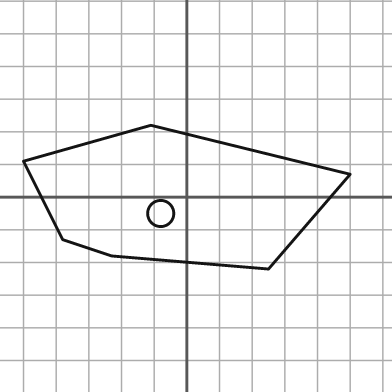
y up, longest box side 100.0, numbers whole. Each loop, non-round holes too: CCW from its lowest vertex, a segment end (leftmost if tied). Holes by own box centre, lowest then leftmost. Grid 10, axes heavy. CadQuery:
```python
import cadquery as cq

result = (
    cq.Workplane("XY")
    .moveTo(25.0, -22.0)
    .lineTo(50.0, 7.0)
    .lineTo(-11.0, 22.0)
    .lineTo(-50.0, 11.0)
    .lineTo(-38.0, -13.0)
    .lineTo(-23.0, -18.0)
    .close()
    .moveTo(-8.0, -5.0)
    .circle(4.0)
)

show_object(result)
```